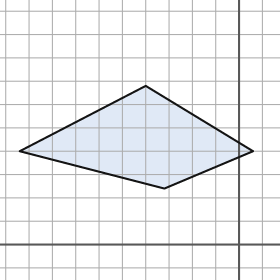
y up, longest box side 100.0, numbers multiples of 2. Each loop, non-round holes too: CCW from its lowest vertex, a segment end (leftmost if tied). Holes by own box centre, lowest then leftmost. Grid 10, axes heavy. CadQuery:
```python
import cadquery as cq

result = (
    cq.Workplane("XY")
    .moveTo(-32.0, 24.0)
    .lineTo(6.0, 40.0)
    .lineTo(-40.0, 68.0)
    .lineTo(-94.0, 40.0)
    .close()
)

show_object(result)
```